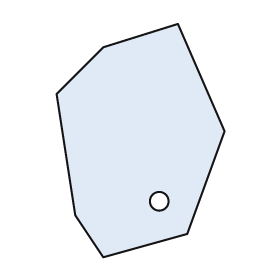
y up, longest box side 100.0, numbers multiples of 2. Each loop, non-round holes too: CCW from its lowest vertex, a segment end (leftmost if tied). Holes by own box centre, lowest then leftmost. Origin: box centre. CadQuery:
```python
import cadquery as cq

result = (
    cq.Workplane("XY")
    .moveTo(-16.0, -50.0)
    .lineTo(20.0, -40.0)
    .lineTo(36.0, 4.0)
    .lineTo(16.0, 50.0)
    .lineTo(-16.0, 40.0)
    .lineTo(-36.0, 20.0)
    .lineTo(-28.0, -32.0)
    .close()
    .moveTo(8.0, -26.0)
    .circle(4.0)
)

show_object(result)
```